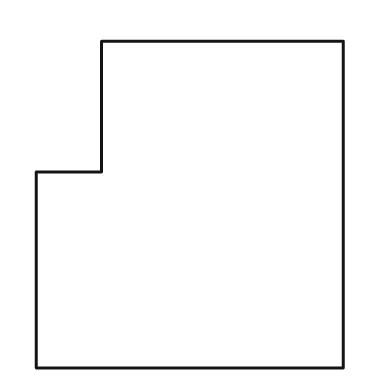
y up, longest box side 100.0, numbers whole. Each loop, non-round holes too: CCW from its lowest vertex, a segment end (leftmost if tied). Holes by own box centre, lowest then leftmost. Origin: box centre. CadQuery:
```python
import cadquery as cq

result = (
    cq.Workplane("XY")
    .moveTo(-47.0, -50.0)
    .lineTo(47.0, -50.0)
    .lineTo(47.0, 50.0)
    .lineTo(-27.0, 50.0)
    .lineTo(-27.0, 10.0)
    .lineTo(-47.0, 10.0)
    .close()
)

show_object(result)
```